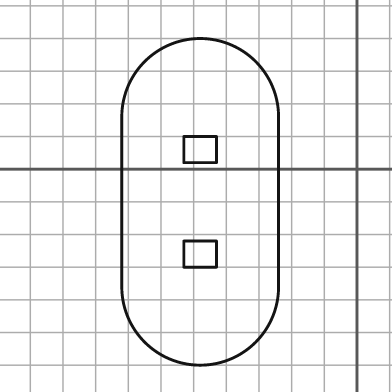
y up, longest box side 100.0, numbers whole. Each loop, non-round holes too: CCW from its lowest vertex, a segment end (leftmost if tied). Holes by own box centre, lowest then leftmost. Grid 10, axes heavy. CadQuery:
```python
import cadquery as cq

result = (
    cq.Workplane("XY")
    .moveTo(-72.0, -36.0)
    .threePointArc((-48.0, -60.0), (-24.0, -36.0))
    .lineTo(-24.0, 16.0)
    .threePointArc((-48.0, 40.0), (-72.0, 16.0))
    .close()
    .moveTo(-53.0, -30.0)
    .lineTo(-43.0, -30.0)
    .lineTo(-43.0, -22.0)
    .lineTo(-53.0, -22.0)
    .close()
    .moveTo(-53.0, 2.0)
    .lineTo(-43.0, 2.0)
    .lineTo(-43.0, 10.0)
    .lineTo(-53.0, 10.0)
    .close()
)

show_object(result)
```